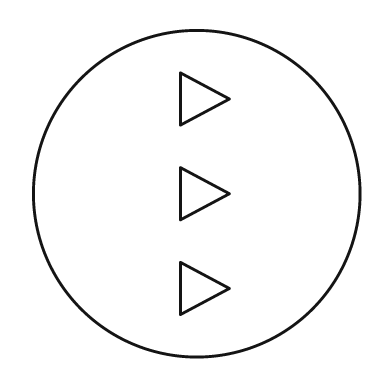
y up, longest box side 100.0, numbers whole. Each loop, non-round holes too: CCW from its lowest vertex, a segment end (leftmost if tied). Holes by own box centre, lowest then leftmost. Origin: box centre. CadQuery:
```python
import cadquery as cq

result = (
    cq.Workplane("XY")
    .moveTo(0.0, 0.0)
    .circle(50.0)
    .moveTo(-5.0, -37.0)
    .lineTo(10.0, -29.0)
    .lineTo(-5.0, -21.0)
    .close()
    .moveTo(-5.0, -8.0)
    .lineTo(10.0, 0.0)
    .lineTo(-5.0, 8.0)
    .close()
    .moveTo(-5.0, 21.0)
    .lineTo(10.0, 29.0)
    .lineTo(-5.0, 37.0)
    .close()
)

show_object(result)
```